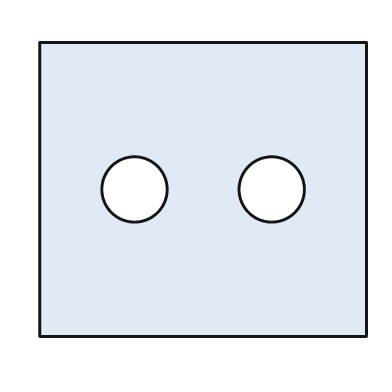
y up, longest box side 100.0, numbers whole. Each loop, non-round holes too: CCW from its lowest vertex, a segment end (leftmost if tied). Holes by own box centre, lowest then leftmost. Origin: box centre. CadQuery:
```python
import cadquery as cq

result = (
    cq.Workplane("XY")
    .moveTo(-50.0, -45.0)
    .lineTo(50.0, -45.0)
    .lineTo(50.0, 45.0)
    .lineTo(-50.0, 45.0)
    .close()
    .moveTo(-21.0, 0.0)
    .circle(10.0)
    .moveTo(21.0, 0.0)
    .circle(10.0)
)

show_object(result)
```